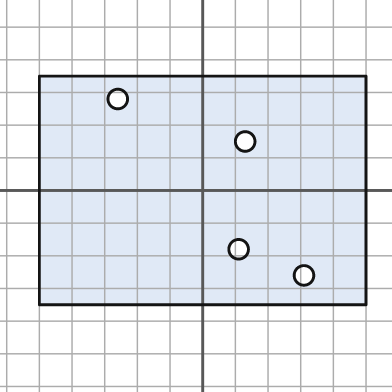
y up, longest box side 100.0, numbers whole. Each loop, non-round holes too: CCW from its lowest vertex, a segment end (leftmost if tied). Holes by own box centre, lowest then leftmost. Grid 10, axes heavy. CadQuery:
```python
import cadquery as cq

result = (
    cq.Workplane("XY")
    .moveTo(-50.0, -35.0)
    .lineTo(50.0, -35.0)
    .lineTo(50.0, 35.0)
    .lineTo(-50.0, 35.0)
    .close()
    .moveTo(31.0, -26.0)
    .circle(3.0)
    .moveTo(11.0, -18.0)
    .circle(3.0)
    .moveTo(13.0, 15.0)
    .circle(3.0)
    .moveTo(-26.0, 28.0)
    .circle(3.0)
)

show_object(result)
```